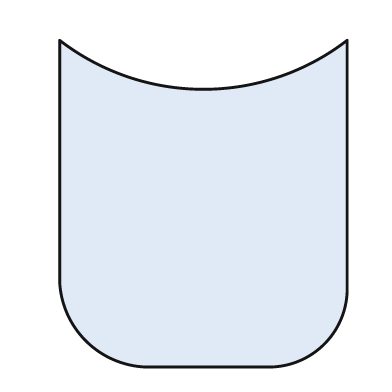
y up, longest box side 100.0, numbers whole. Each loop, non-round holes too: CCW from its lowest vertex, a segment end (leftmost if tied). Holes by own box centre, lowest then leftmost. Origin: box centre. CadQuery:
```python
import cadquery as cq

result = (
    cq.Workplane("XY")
    .moveTo(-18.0, -50.0)
    .lineTo(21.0, -50.0)
    .threePointArc((37.0, -43.0), (44.0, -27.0))
    .lineTo(44.0, 50.0)
    .threePointArc((0.0, 35.0), (-44.0, 50.0))
    .lineTo(-44.0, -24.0)
    .threePointArc((-36.0, -42.0), (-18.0, -50.0))
    .close()
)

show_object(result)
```